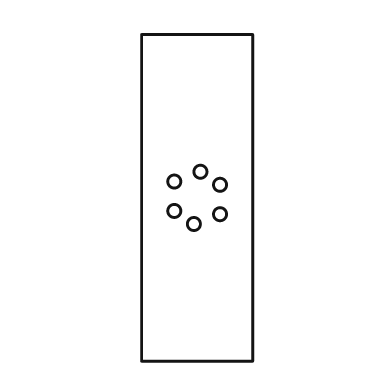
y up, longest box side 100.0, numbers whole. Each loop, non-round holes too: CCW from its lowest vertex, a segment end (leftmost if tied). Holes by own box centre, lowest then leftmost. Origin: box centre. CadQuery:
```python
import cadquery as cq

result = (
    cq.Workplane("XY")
    .moveTo(-17.0, -50.0)
    .lineTo(17.0, -50.0)
    .lineTo(17.0, 50.0)
    .lineTo(-17.0, 50.0)
    .close()
    .moveTo(-1.0, -8.0)
    .circle(2.0)
    .moveTo(7.0, -5.0)
    .circle(2.0)
    .moveTo(-7.0, -4.0)
    .circle(2.0)
    .moveTo(7.0, 4.0)
    .circle(2.0)
    .moveTo(-7.0, 5.0)
    .circle(2.0)
    .moveTo(1.0, 8.0)
    .circle(2.0)
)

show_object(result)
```